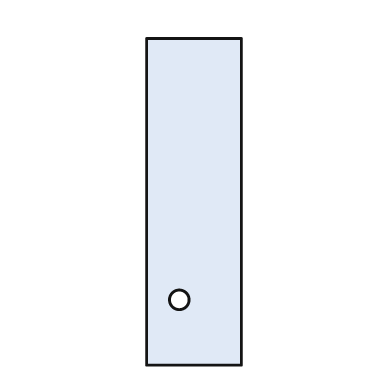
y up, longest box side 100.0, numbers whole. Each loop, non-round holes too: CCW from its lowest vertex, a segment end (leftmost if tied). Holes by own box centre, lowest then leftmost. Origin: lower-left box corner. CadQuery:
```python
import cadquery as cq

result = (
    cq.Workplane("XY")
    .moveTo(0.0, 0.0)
    .lineTo(29.0, 0.0)
    .lineTo(29.0, 100.0)
    .lineTo(0.0, 100.0)
    .close()
    .moveTo(10.0, 20.0)
    .circle(3.0)
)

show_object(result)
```